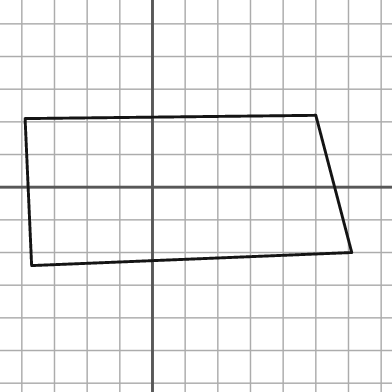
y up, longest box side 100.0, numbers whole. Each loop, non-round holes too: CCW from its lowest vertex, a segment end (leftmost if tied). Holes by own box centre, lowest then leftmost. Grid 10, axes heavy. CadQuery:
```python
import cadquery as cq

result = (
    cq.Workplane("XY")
    .moveTo(-37.0, -24.0)
    .lineTo(61.0, -20.0)
    .lineTo(50.0, 22.0)
    .lineTo(-39.0, 21.0)
    .close()
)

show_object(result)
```